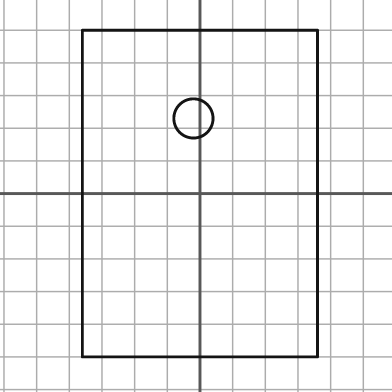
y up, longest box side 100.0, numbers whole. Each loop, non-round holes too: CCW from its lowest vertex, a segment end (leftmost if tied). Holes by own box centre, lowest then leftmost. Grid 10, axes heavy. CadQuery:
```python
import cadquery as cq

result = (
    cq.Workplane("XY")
    .moveTo(-36.0, -50.0)
    .lineTo(36.0, -50.0)
    .lineTo(36.0, 50.0)
    .lineTo(-36.0, 50.0)
    .close()
    .moveTo(-2.0, 23.0)
    .circle(6.0)
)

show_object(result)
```